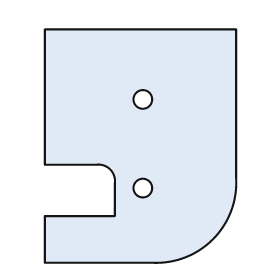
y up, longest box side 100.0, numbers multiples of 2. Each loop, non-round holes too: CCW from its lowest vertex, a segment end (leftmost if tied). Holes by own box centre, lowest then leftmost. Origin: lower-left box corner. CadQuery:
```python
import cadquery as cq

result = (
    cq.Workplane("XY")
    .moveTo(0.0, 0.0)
    .lineTo(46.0, 0.0)
    .threePointArc((72.0, 10.0), (82.0, 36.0))
    .lineTo(82.0, 100.0)
    .lineTo(0.0, 100.0)
    .lineTo(0.0, 42.0)
    .lineTo(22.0, 42.0)
    .threePointArc((28.0, 40.0), (30.0, 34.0))
    .lineTo(30.0, 20.0)
    .lineTo(0.0, 20.0)
    .close()
    .moveTo(42.0, 32.0)
    .circle(4.0)
    .moveTo(42.0, 70.0)
    .circle(4.0)
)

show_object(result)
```